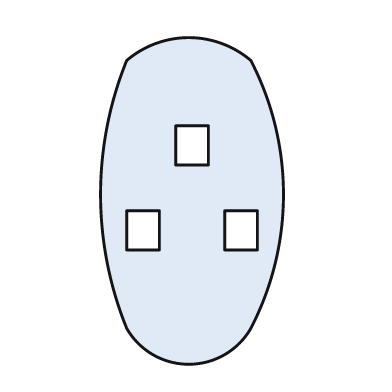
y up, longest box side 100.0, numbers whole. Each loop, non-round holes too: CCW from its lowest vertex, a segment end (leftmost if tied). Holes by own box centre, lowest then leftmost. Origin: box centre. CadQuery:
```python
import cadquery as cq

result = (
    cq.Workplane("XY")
    .moveTo(-20.0, -39.0)
    .threePointArc((-1.0, -50.0), (18.0, -39.0))
    .threePointArc((28.0, 2.0), (18.0, 43.0))
    .threePointArc((-1.0, 50.0), (-20.0, 43.0))
    .threePointArc((-28.0, 2.0), (-20.0, -39.0))
    .close()
    .moveTo(-20.0, -15.0)
    .lineTo(-10.0, -15.0)
    .lineTo(-10.0, -3.0)
    .lineTo(-20.0, -3.0)
    .close()
    .moveTo(10.0, -15.0)
    .lineTo(20.0, -15.0)
    .lineTo(20.0, -3.0)
    .lineTo(10.0, -3.0)
    .close()
    .moveTo(-5.0, 11.0)
    .lineTo(5.0, 11.0)
    .lineTo(5.0, 23.0)
    .lineTo(-5.0, 23.0)
    .close()
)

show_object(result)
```